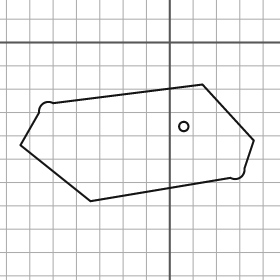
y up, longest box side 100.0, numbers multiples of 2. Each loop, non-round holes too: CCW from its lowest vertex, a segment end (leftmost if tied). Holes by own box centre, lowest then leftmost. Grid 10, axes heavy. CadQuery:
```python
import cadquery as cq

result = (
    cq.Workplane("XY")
    .moveTo(-34.0, -68.0)
    .lineTo(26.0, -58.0)
    .threePointArc((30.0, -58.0), (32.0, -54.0))
    .lineTo(36.0, -42.0)
    .lineTo(14.0, -18.0)
    .lineTo(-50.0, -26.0)
    .threePointArc((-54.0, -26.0), (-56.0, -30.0))
    .lineTo(-64.0, -44.0)
    .close()
    .moveTo(6.0, -36.0)
    .circle(2.0)
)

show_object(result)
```